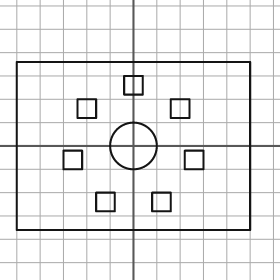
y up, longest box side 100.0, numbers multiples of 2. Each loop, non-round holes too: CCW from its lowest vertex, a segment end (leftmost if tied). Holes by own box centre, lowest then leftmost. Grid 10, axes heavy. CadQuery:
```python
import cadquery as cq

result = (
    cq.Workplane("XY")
    .moveTo(-50.0, -36.0)
    .lineTo(50.0, -36.0)
    .lineTo(50.0, 36.0)
    .lineTo(-50.0, 36.0)
    .close()
    .moveTo(-16.0, -28.0)
    .lineTo(-8.0, -28.0)
    .lineTo(-8.0, -20.0)
    .lineTo(-16.0, -20.0)
    .close()
    .moveTo(8.0, -28.0)
    .lineTo(16.0, -28.0)
    .lineTo(16.0, -20.0)
    .lineTo(8.0, -20.0)
    .close()
    .moveTo(-30.0, -10.0)
    .lineTo(-22.0, -10.0)
    .lineTo(-22.0, -2.0)
    .lineTo(-30.0, -2.0)
    .close()
    .moveTo(22.0, -10.0)
    .lineTo(30.0, -10.0)
    .lineTo(30.0, -2.0)
    .lineTo(22.0, -2.0)
    .close()
    .moveTo(0.0, 0.0)
    .circle(10.0)
    .moveTo(-24.0, 12.0)
    .lineTo(-16.0, 12.0)
    .lineTo(-16.0, 20.0)
    .lineTo(-24.0, 20.0)
    .close()
    .moveTo(16.0, 12.0)
    .lineTo(24.0, 12.0)
    .lineTo(24.0, 20.0)
    .lineTo(16.0, 20.0)
    .close()
    .moveTo(-4.0, 22.0)
    .lineTo(4.0, 22.0)
    .lineTo(4.0, 30.0)
    .lineTo(-4.0, 30.0)
    .close()
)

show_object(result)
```